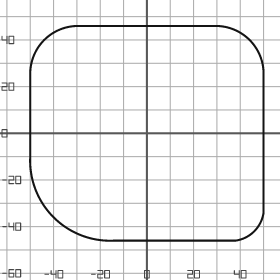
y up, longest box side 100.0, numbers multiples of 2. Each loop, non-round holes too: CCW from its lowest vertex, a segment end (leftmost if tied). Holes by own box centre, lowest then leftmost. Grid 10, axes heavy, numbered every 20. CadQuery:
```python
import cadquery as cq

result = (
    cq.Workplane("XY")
    .moveTo(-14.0, -46.0)
    .lineTo(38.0, -46.0)
    .threePointArc((46.0, -42.0), (50.0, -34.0))
    .lineTo(50.0, 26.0)
    .threePointArc((44.0, 40.0), (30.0, 46.0))
    .lineTo(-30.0, 46.0)
    .threePointArc((-44.0, 40.0), (-50.0, 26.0))
    .lineTo(-50.0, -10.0)
    .threePointArc((-40.0, -36.0), (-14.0, -46.0))
    .close()
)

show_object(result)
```